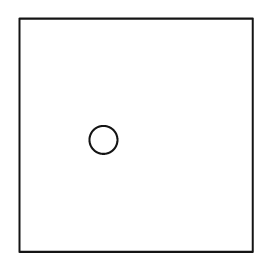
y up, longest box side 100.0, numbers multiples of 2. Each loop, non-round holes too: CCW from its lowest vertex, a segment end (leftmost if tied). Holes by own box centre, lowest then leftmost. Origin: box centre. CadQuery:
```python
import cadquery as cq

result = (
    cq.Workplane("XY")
    .moveTo(-50.0, -50.0)
    .lineTo(50.0, -50.0)
    .lineTo(50.0, 50.0)
    .lineTo(-50.0, 50.0)
    .close()
    .moveTo(-14.0, -2.0)
    .circle(6.0)
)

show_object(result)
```